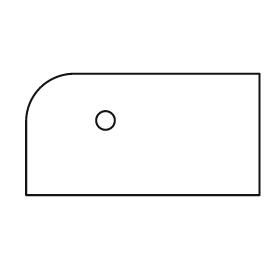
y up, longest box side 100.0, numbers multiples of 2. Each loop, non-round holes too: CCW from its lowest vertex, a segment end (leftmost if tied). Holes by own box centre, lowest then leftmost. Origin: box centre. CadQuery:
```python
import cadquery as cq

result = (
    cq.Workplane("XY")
    .moveTo(-50.0, -26.0)
    .lineTo(50.0, -26.0)
    .lineTo(50.0, 26.0)
    .lineTo(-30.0, 26.0)
    .threePointArc((-44.0, 20.0), (-50.0, 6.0))
    .close()
    .moveTo(-16.0, 6.0)
    .circle(4.0)
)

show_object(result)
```